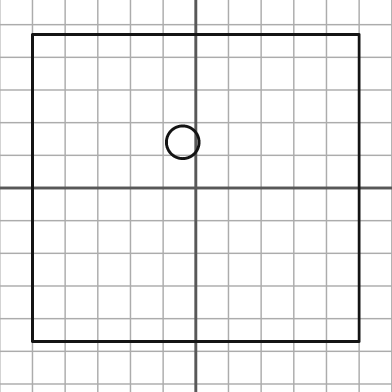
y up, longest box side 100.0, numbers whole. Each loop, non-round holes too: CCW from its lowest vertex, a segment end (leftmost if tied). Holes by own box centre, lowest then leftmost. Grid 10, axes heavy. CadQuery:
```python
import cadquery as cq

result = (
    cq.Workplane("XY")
    .moveTo(-50.0, -47.0)
    .lineTo(50.0, -47.0)
    .lineTo(50.0, 47.0)
    .lineTo(-50.0, 47.0)
    .close()
    .moveTo(-4.0, 14.0)
    .circle(5.0)
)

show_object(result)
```